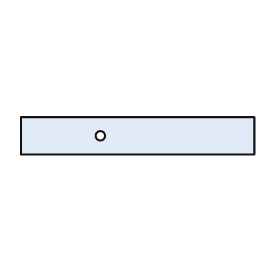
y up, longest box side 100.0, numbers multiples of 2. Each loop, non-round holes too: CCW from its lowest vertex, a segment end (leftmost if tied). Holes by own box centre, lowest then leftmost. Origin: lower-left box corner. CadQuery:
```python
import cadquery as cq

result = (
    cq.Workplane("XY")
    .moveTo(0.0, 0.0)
    .lineTo(100.0, 0.0)
    .lineTo(100.0, 16.0)
    .lineTo(0.0, 16.0)
    .close()
    .moveTo(34.0, 8.0)
    .circle(2.0)
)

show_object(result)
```